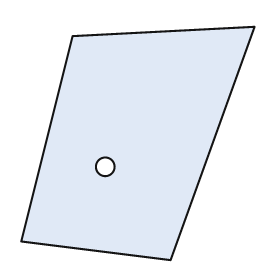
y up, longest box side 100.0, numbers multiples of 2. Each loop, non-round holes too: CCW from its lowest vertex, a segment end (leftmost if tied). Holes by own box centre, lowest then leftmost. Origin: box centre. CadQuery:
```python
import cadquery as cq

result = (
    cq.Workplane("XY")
    .moveTo(14.0, -50.0)
    .lineTo(50.0, 50.0)
    .lineTo(-28.0, 46.0)
    .lineTo(-50.0, -42.0)
    .close()
    .moveTo(-14.0, -10.0)
    .circle(4.0)
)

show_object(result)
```